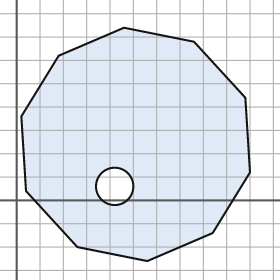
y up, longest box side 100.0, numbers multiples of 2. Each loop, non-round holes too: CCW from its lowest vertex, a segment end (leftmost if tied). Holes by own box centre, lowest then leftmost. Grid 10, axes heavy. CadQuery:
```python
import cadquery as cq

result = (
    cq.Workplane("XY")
    .moveTo(56.0, -26.0)
    .lineTo(84.0, -14.0)
    .lineTo(100.0, 12.0)
    .lineTo(98.0, 44.0)
    .lineTo(76.0, 68.0)
    .lineTo(46.0, 74.0)
    .lineTo(18.0, 62.0)
    .lineTo(2.0, 36.0)
    .lineTo(4.0, 4.0)
    .lineTo(26.0, -20.0)
    .close()
    .moveTo(42.0, 6.0)
    .circle(8.0)
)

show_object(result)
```